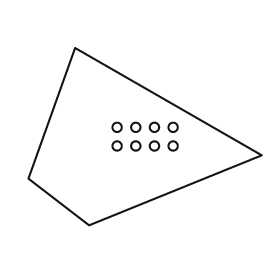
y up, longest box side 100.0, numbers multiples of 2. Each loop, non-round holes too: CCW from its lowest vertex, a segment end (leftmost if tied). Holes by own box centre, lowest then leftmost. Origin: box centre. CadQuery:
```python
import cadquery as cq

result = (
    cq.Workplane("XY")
    .moveTo(-24.0, -38.0)
    .lineTo(50.0, -8.0)
    .lineTo(-30.0, 38.0)
    .lineTo(-50.0, -18.0)
    .close()
    .moveTo(-12.0, -4.0)
    .circle(2.0)
    .moveTo(-4.0, -4.0)
    .circle(2.0)
    .moveTo(4.0, -4.0)
    .circle(2.0)
    .moveTo(12.0, -4.0)
    .circle(2.0)
    .moveTo(-12.0, 4.0)
    .circle(2.0)
    .moveTo(-4.0, 4.0)
    .circle(2.0)
    .moveTo(4.0, 4.0)
    .circle(2.0)
    .moveTo(12.0, 4.0)
    .circle(2.0)
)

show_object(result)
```